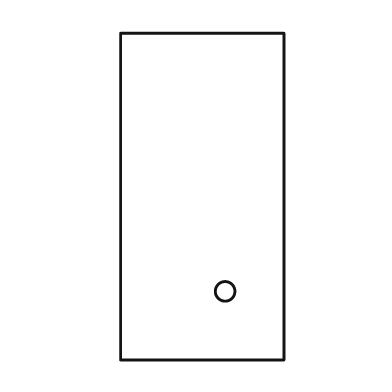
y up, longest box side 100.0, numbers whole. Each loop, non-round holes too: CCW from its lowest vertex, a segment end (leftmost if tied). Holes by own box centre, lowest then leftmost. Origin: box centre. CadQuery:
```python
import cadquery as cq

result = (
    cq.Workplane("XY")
    .moveTo(-25.0, -50.0)
    .lineTo(25.0, -50.0)
    .lineTo(25.0, 50.0)
    .lineTo(-25.0, 50.0)
    .close()
    .moveTo(7.0, -29.0)
    .circle(3.0)
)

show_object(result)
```